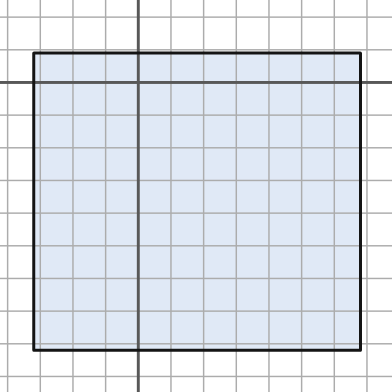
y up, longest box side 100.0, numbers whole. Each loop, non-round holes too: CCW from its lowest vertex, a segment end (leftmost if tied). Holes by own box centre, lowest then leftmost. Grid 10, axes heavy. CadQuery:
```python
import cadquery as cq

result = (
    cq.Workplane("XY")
    .moveTo(-32.0, -82.0)
    .lineTo(68.0, -82.0)
    .lineTo(68.0, 9.0)
    .lineTo(-32.0, 9.0)
    .close()
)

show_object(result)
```